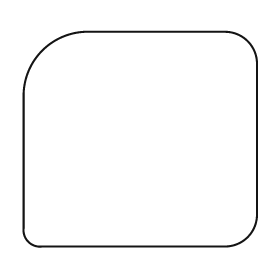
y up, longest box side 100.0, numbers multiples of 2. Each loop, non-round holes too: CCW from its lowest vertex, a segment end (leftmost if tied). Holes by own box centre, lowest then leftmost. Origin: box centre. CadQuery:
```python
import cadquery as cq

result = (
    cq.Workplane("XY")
    .moveTo(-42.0, -46.0)
    .lineTo(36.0, -46.0)
    .threePointArc((46.0, -42.0), (50.0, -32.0))
    .lineTo(50.0, 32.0)
    .threePointArc((46.0, 42.0), (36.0, 46.0))
    .lineTo(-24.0, 46.0)
    .threePointArc((-42.0, 38.0), (-50.0, 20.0))
    .lineTo(-50.0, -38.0)
    .threePointArc((-48.0, -44.0), (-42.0, -46.0))
    .close()
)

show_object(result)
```